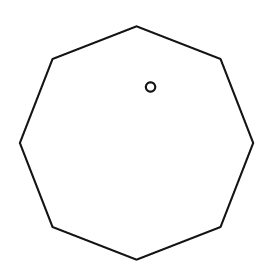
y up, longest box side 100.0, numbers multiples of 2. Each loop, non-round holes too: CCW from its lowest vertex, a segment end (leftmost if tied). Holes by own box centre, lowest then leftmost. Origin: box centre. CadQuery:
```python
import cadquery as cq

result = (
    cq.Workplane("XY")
    .moveTo(0.0, -50.0)
    .lineTo(36.0, -36.0)
    .lineTo(50.0, 0.0)
    .lineTo(36.0, 36.0)
    .lineTo(0.0, 50.0)
    .lineTo(-36.0, 36.0)
    .lineTo(-50.0, 0.0)
    .lineTo(-36.0, -36.0)
    .close()
    .moveTo(6.0, 24.0)
    .circle(2.0)
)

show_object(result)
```